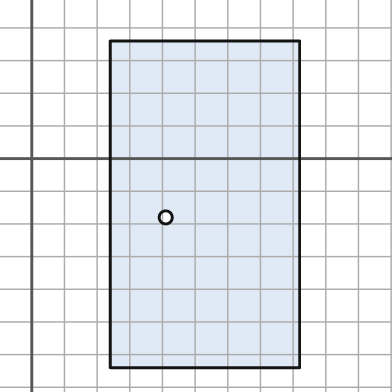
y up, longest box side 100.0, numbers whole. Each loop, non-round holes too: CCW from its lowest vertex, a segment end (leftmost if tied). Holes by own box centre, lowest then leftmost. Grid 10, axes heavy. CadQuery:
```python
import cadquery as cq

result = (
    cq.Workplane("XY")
    .moveTo(24.0, -64.0)
    .lineTo(82.0, -64.0)
    .lineTo(82.0, 36.0)
    .lineTo(24.0, 36.0)
    .close()
    .moveTo(41.0, -18.0)
    .circle(2.0)
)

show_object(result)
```